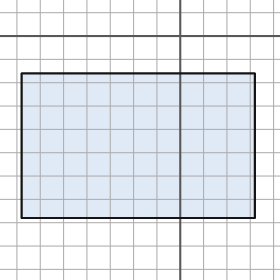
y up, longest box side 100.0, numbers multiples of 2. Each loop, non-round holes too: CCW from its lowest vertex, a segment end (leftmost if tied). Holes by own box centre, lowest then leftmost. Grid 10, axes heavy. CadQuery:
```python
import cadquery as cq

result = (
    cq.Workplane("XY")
    .moveTo(-68.0, -78.0)
    .lineTo(32.0, -78.0)
    .lineTo(32.0, -16.0)
    .lineTo(-68.0, -16.0)
    .close()
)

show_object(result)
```